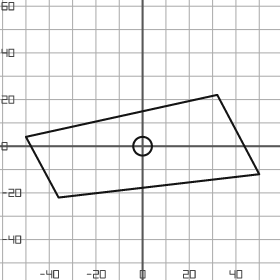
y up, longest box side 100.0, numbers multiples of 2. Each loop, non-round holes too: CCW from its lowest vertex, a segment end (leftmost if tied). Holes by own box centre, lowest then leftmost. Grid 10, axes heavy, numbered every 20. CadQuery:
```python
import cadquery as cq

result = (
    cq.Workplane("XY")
    .moveTo(-36.0, -22.0)
    .lineTo(50.0, -12.0)
    .lineTo(32.0, 22.0)
    .lineTo(-50.0, 4.0)
    .close()
    .moveTo(0.0, 0.0)
    .circle(4.0)
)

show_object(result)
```